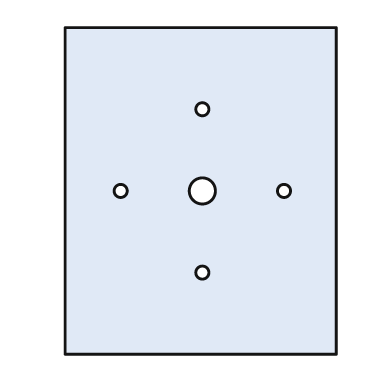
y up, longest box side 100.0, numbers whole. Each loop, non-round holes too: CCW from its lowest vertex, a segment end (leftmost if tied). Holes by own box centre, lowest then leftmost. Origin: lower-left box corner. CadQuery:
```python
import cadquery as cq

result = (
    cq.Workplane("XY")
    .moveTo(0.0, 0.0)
    .lineTo(83.0, 0.0)
    .lineTo(83.0, 100.0)
    .lineTo(0.0, 100.0)
    .close()
    .moveTo(42.0, 25.0)
    .circle(2.0)
    .moveTo(17.0, 50.0)
    .circle(2.0)
    .moveTo(42.0, 50.0)
    .circle(4.0)
    .moveTo(67.0, 50.0)
    .circle(2.0)
    .moveTo(42.0, 75.0)
    .circle(2.0)
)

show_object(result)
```